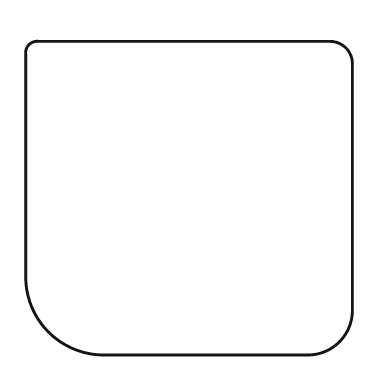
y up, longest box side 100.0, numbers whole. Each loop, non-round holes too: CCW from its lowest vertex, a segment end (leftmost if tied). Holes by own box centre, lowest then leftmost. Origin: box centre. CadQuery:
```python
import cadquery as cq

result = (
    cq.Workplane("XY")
    .moveTo(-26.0, -48.0)
    .lineTo(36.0, -48.0)
    .threePointArc((46.0, -44.0), (50.0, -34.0))
    .lineTo(50.0, 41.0)
    .threePointArc((48.0, 46.0), (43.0, 48.0))
    .lineTo(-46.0, 48.0)
    .threePointArc((-49.0, 47.0), (-50.0, 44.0))
    .lineTo(-50.0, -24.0)
    .threePointArc((-43.0, -41.0), (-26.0, -48.0))
    .close()
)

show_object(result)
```